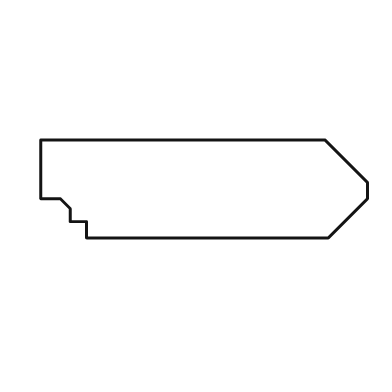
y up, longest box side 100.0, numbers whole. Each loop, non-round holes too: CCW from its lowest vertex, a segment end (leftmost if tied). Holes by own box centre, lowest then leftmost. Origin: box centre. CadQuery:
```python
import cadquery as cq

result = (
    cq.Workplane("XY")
    .moveTo(-36.0, -15.0)
    .lineTo(38.0, -15.0)
    .lineTo(50.0, -3.0)
    .lineTo(50.0, 2.0)
    .lineTo(37.0, 15.0)
    .lineTo(-50.0, 15.0)
    .lineTo(-50.0, -3.0)
    .lineTo(-44.0, -3.0)
    .lineTo(-41.0, -6.0)
    .lineTo(-41.0, -10.0)
    .lineTo(-36.0, -10.0)
    .close()
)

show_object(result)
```